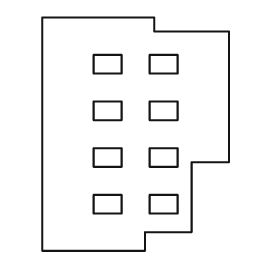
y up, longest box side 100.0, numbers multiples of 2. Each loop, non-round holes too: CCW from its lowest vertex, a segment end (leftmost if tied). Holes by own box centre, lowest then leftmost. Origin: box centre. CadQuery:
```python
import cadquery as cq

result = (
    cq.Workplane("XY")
    .moveTo(-40.0, -50.0)
    .lineTo(4.0, -50.0)
    .lineTo(4.0, -42.0)
    .lineTo(24.0, -42.0)
    .lineTo(24.0, -12.0)
    .lineTo(40.0, -12.0)
    .lineTo(40.0, 44.0)
    .lineTo(8.0, 44.0)
    .lineTo(8.0, 50.0)
    .lineTo(-40.0, 50.0)
    .close()
    .moveTo(-18.0, -34.0)
    .lineTo(-6.0, -34.0)
    .lineTo(-6.0, -26.0)
    .lineTo(-18.0, -26.0)
    .close()
    .moveTo(6.0, -34.0)
    .lineTo(18.0, -34.0)
    .lineTo(18.0, -26.0)
    .lineTo(6.0, -26.0)
    .close()
    .moveTo(-18.0, -14.0)
    .lineTo(-6.0, -14.0)
    .lineTo(-6.0, -6.0)
    .lineTo(-18.0, -6.0)
    .close()
    .moveTo(6.0, -14.0)
    .lineTo(18.0, -14.0)
    .lineTo(18.0, -6.0)
    .lineTo(6.0, -6.0)
    .close()
    .moveTo(-18.0, 6.0)
    .lineTo(-6.0, 6.0)
    .lineTo(-6.0, 14.0)
    .lineTo(-18.0, 14.0)
    .close()
    .moveTo(6.0, 6.0)
    .lineTo(18.0, 6.0)
    .lineTo(18.0, 14.0)
    .lineTo(6.0, 14.0)
    .close()
    .moveTo(-18.0, 26.0)
    .lineTo(-6.0, 26.0)
    .lineTo(-6.0, 34.0)
    .lineTo(-18.0, 34.0)
    .close()
    .moveTo(6.0, 26.0)
    .lineTo(18.0, 26.0)
    .lineTo(18.0, 34.0)
    .lineTo(6.0, 34.0)
    .close()
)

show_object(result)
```